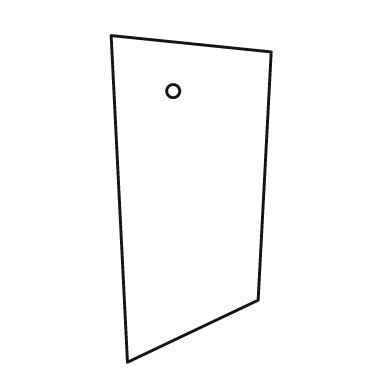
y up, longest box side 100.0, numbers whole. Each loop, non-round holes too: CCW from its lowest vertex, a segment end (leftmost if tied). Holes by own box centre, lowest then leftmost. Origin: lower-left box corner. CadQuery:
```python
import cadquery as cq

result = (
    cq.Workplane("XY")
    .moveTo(5.0, 0.0)
    .lineTo(45.0, 19.0)
    .lineTo(49.0, 95.0)
    .lineTo(0.0, 100.0)
    .close()
    .moveTo(19.0, 83.0)
    .circle(2.0)
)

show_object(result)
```